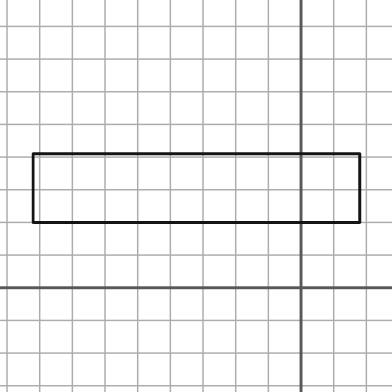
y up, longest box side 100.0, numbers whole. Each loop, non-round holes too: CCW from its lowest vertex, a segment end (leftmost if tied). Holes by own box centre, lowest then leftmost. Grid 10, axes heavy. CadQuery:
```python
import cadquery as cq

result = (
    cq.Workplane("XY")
    .moveTo(-82.0, 20.0)
    .lineTo(18.0, 20.0)
    .lineTo(18.0, 41.0)
    .lineTo(-82.0, 41.0)
    .close()
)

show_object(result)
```